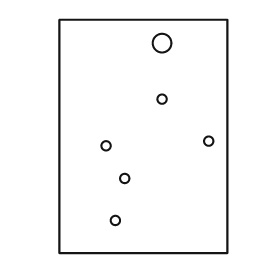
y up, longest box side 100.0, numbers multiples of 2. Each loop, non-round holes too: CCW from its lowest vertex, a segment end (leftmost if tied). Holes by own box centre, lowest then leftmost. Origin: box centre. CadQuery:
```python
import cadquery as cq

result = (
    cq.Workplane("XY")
    .moveTo(-36.0, -50.0)
    .lineTo(36.0, -50.0)
    .lineTo(36.0, 50.0)
    .lineTo(-36.0, 50.0)
    .close()
    .moveTo(-12.0, -36.0)
    .circle(2.0)
    .moveTo(-8.0, -18.0)
    .circle(2.0)
    .moveTo(-16.0, -4.0)
    .circle(2.0)
    .moveTo(28.0, -2.0)
    .circle(2.0)
    .moveTo(8.0, 16.0)
    .circle(2.0)
    .moveTo(8.0, 40.0)
    .circle(4.0)
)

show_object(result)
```